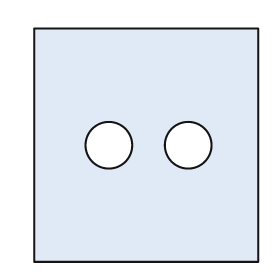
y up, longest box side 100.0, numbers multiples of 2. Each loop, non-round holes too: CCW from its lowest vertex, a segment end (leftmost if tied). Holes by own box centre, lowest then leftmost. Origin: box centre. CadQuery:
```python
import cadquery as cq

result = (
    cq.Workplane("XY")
    .moveTo(-48.0, -50.0)
    .lineTo(48.0, -50.0)
    .lineTo(48.0, 50.0)
    .lineTo(-48.0, 50.0)
    .close()
    .moveTo(-16.0, 0.0)
    .circle(10.0)
    .moveTo(18.0, 0.0)
    .circle(10.0)
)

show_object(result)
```